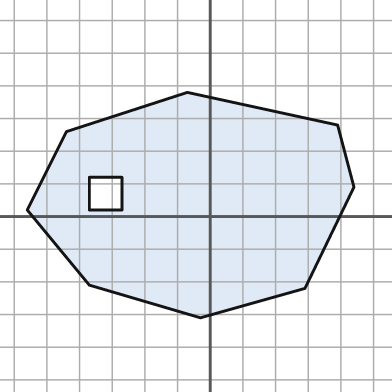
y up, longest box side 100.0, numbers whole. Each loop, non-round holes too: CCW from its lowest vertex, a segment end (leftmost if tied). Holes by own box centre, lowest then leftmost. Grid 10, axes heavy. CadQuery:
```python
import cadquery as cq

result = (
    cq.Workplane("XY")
    .moveTo(-3.0, -31.0)
    .lineTo(29.0, -22.0)
    .lineTo(44.0, 9.0)
    .lineTo(39.0, 28.0)
    .lineTo(-7.0, 38.0)
    .lineTo(-44.0, 26.0)
    .lineTo(-56.0, 2.0)
    .lineTo(-37.0, -21.0)
    .close()
    .moveTo(-37.0, 2.0)
    .lineTo(-27.0, 2.0)
    .lineTo(-27.0, 12.0)
    .lineTo(-37.0, 12.0)
    .close()
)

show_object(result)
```